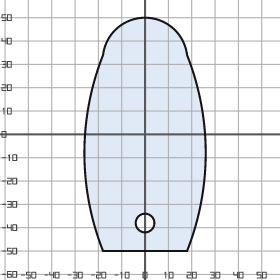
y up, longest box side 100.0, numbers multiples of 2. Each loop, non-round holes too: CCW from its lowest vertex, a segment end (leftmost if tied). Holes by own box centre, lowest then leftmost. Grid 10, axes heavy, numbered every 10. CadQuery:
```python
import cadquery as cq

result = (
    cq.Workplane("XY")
    .moveTo(-18.0, -50.0)
    .lineTo(18.0, -50.0)
    .threePointArc((26.0, -8.0), (18.0, 34.0))
    .threePointArc((0.0, 50.0), (-18.0, 34.0))
    .threePointArc((-26.0, -8.0), (-18.0, -50.0))
    .close()
    .moveTo(0.0, -38.0)
    .circle(4.0)
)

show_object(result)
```